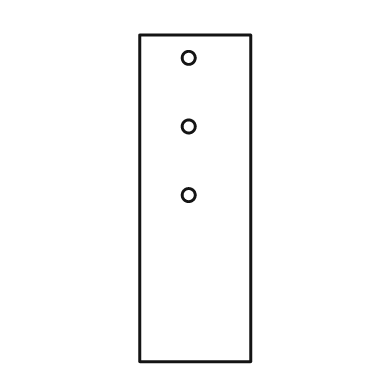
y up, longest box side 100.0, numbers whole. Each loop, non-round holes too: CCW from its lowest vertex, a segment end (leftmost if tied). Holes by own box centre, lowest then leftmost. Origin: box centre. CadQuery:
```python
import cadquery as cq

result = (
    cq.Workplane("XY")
    .moveTo(-17.0, -50.0)
    .lineTo(17.0, -50.0)
    .lineTo(17.0, 50.0)
    .lineTo(-17.0, 50.0)
    .close()
    .moveTo(-2.0, 1.0)
    .circle(2.0)
    .moveTo(-2.0, 22.0)
    .circle(2.0)
    .moveTo(-2.0, 43.0)
    .circle(2.0)
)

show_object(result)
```